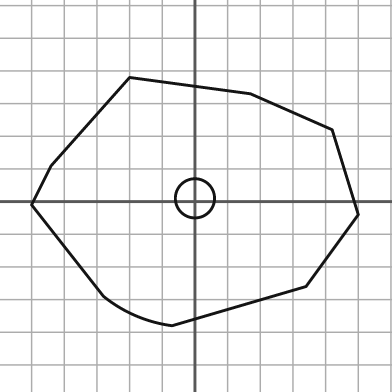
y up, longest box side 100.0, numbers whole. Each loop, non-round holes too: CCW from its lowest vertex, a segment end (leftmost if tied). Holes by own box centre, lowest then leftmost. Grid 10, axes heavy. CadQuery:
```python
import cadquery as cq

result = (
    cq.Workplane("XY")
    .moveTo(-7.0, -38.0)
    .lineTo(34.0, -26.0)
    .lineTo(50.0, -4.0)
    .lineTo(42.0, 22.0)
    .lineTo(17.0, 33.0)
    .lineTo(-20.0, 38.0)
    .lineTo(-44.0, 11.0)
    .lineTo(-50.0, -1.0)
    .lineTo(-28.0, -29.0)
    .threePointArc((-18.0, -35.0), (-7.0, -38.0))
    .close()
    .moveTo(0.0, 1.0)
    .circle(6.0)
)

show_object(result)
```